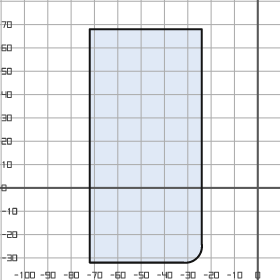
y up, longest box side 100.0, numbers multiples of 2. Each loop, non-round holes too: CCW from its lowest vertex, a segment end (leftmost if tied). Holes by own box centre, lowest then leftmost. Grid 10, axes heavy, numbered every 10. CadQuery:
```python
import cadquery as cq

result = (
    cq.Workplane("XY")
    .moveTo(-72.0, -32.0)
    .lineTo(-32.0, -32.0)
    .threePointArc((-26.0, -30.0), (-24.0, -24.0))
    .lineTo(-24.0, 68.0)
    .lineTo(-72.0, 68.0)
    .close()
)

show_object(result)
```